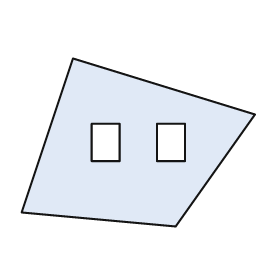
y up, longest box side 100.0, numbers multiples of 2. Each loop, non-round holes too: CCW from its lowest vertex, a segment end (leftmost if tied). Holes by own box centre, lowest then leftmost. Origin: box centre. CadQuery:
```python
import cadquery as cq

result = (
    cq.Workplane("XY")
    .moveTo(16.0, -36.0)
    .lineTo(50.0, 12.0)
    .lineTo(-28.0, 36.0)
    .lineTo(-50.0, -30.0)
    .close()
    .moveTo(-20.0, -8.0)
    .lineTo(-8.0, -8.0)
    .lineTo(-8.0, 8.0)
    .lineTo(-20.0, 8.0)
    .close()
    .moveTo(8.0, -8.0)
    .lineTo(20.0, -8.0)
    .lineTo(20.0, 8.0)
    .lineTo(8.0, 8.0)
    .close()
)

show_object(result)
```